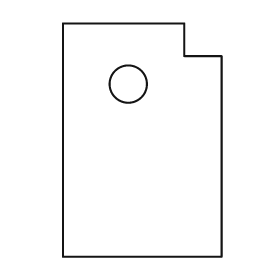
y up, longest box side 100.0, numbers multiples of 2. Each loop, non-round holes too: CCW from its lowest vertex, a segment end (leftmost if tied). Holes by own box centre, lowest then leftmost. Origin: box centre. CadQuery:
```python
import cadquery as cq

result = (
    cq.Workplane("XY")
    .moveTo(-34.0, -50.0)
    .lineTo(34.0, -50.0)
    .lineTo(34.0, 36.0)
    .lineTo(18.0, 36.0)
    .lineTo(18.0, 50.0)
    .lineTo(-34.0, 50.0)
    .close()
    .moveTo(-6.0, 24.0)
    .circle(8.0)
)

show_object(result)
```